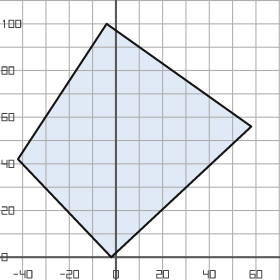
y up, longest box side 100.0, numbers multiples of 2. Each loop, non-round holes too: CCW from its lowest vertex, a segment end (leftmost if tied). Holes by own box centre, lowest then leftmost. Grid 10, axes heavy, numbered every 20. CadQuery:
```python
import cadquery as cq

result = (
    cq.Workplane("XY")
    .moveTo(-2.0, 0.0)
    .lineTo(58.0, 56.0)
    .lineTo(-4.0, 100.0)
    .lineTo(-42.0, 42.0)
    .close()
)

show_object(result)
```